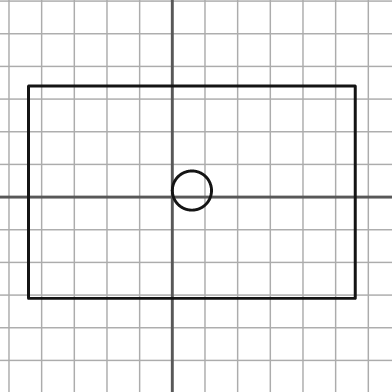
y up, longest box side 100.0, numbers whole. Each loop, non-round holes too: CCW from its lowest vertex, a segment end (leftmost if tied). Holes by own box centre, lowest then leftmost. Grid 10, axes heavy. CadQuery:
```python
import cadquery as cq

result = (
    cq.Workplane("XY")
    .moveTo(-44.0, -31.0)
    .lineTo(56.0, -31.0)
    .lineTo(56.0, 34.0)
    .lineTo(-44.0, 34.0)
    .close()
    .moveTo(6.0, 2.0)
    .circle(6.0)
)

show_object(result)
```